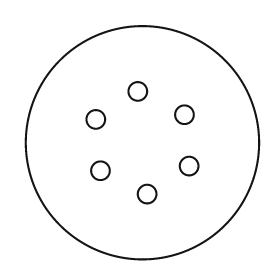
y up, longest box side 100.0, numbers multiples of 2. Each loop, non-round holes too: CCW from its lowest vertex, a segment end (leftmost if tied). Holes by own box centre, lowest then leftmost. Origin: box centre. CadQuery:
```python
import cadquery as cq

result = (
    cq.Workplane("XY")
    .moveTo(0.0, 0.0)
    .circle(50.0)
    .moveTo(2.0, -22.0)
    .circle(4.0)
    .moveTo(-18.0, -12.0)
    .circle(4.0)
    .moveTo(20.0, -10.0)
    .circle(4.0)
    .moveTo(-20.0, 10.0)
    .circle(4.0)
    .moveTo(18.0, 12.0)
    .circle(4.0)
    .moveTo(-2.0, 22.0)
    .circle(4.0)
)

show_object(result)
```